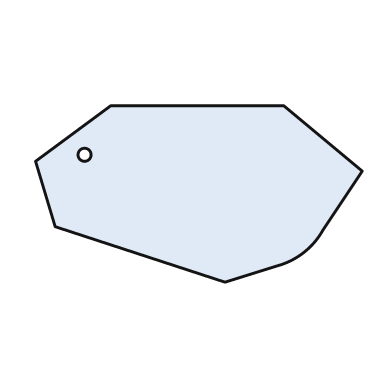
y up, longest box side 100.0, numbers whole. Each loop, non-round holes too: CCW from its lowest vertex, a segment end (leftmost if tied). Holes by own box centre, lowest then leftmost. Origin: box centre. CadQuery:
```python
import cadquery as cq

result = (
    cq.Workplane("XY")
    .moveTo(8.0, -27.0)
    .lineTo(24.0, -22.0)
    .threePointArc((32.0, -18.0), (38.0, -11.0))
    .lineTo(50.0, 7.0)
    .lineTo(26.0, 27.0)
    .lineTo(-27.0, 27.0)
    .lineTo(-50.0, 10.0)
    .lineTo(-44.0, -10.0)
    .close()
    .moveTo(-35.0, 12.0)
    .circle(2.0)
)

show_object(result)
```